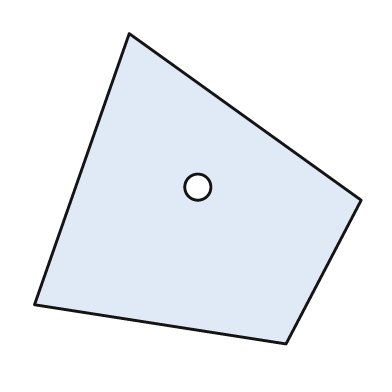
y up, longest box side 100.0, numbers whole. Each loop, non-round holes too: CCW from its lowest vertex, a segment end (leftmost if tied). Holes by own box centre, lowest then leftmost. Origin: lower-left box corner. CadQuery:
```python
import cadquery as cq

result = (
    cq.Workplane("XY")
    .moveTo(77.0, 0.0)
    .lineTo(100.0, 44.0)
    .lineTo(29.0, 95.0)
    .lineTo(0.0, 12.0)
    .close()
    .moveTo(50.0, 48.0)
    .circle(4.0)
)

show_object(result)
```